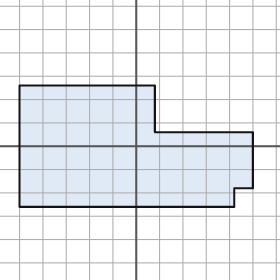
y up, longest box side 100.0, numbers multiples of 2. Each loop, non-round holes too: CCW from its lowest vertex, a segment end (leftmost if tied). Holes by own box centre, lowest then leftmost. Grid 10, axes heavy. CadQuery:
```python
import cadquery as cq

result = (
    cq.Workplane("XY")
    .moveTo(-50.0, -26.0)
    .lineTo(42.0, -26.0)
    .lineTo(42.0, -18.0)
    .lineTo(50.0, -18.0)
    .lineTo(50.0, 6.0)
    .lineTo(8.0, 6.0)
    .lineTo(8.0, 26.0)
    .lineTo(-50.0, 26.0)
    .close()
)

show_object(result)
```